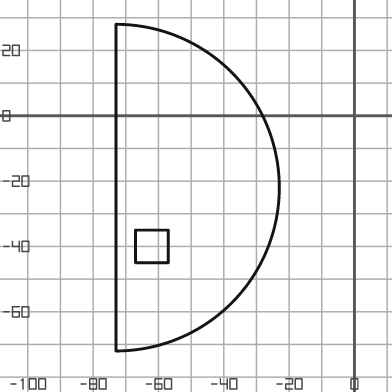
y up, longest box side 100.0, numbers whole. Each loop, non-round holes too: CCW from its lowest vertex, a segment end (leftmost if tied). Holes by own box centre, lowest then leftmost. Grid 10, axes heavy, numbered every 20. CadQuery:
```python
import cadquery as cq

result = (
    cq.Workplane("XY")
    .moveTo(-73.0, -72.0)
    .threePointArc((-23.0, -22.0), (-73.0, 28.0))
    .close()
    .moveTo(-67.0, -45.0)
    .lineTo(-57.0, -45.0)
    .lineTo(-57.0, -35.0)
    .lineTo(-67.0, -35.0)
    .close()
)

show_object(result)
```